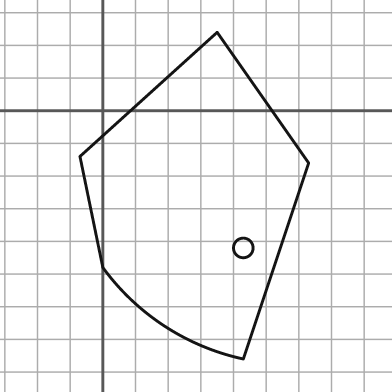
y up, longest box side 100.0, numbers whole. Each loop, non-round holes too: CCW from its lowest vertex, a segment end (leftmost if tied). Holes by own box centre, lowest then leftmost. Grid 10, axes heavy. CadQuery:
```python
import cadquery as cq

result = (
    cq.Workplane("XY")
    .moveTo(43.0, -76.0)
    .lineTo(63.0, -16.0)
    .lineTo(35.0, 24.0)
    .lineTo(-7.0, -14.0)
    .lineTo(0.0, -48.0)
    .threePointArc((19.0, -66.0), (43.0, -76.0))
    .close()
    .moveTo(43.0, -42.0)
    .circle(3.0)
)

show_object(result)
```